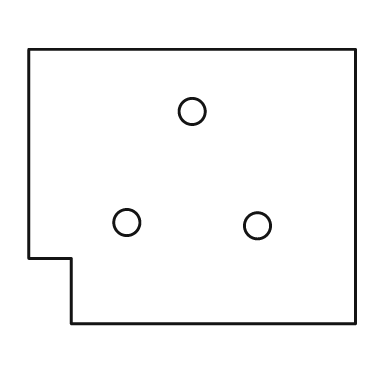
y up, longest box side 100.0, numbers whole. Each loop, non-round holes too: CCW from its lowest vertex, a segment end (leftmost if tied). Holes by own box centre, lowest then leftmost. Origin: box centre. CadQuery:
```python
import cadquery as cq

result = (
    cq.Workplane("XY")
    .moveTo(-37.0, -42.0)
    .lineTo(50.0, -42.0)
    .lineTo(50.0, 42.0)
    .lineTo(-50.0, 42.0)
    .lineTo(-50.0, -22.0)
    .lineTo(-37.0, -22.0)
    .close()
    .moveTo(20.0, -12.0)
    .circle(4.0)
    .moveTo(-20.0, -11.0)
    .circle(4.0)
    .moveTo(0.0, 23.0)
    .circle(4.0)
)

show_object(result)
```